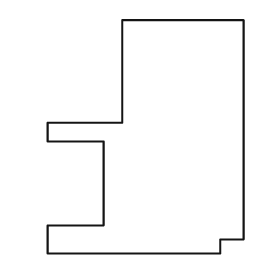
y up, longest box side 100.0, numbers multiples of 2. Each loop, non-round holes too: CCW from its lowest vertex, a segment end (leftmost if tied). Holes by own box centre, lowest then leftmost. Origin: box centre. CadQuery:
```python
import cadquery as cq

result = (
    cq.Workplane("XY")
    .moveTo(-42.0, -50.0)
    .lineTo(32.0, -50.0)
    .lineTo(32.0, -44.0)
    .lineTo(42.0, -44.0)
    .lineTo(42.0, 50.0)
    .lineTo(-10.0, 50.0)
    .lineTo(-10.0, 6.0)
    .lineTo(-42.0, 6.0)
    .lineTo(-42.0, -2.0)
    .lineTo(-18.0, -2.0)
    .lineTo(-18.0, -38.0)
    .lineTo(-42.0, -38.0)
    .close()
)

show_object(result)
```